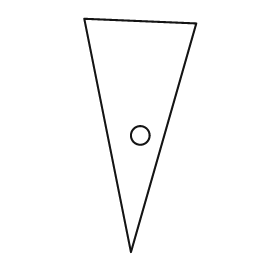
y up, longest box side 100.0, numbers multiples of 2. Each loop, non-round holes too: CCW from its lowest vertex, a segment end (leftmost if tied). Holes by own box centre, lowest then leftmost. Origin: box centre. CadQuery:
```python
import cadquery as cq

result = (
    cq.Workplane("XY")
    .moveTo(-4.0, -50.0)
    .lineTo(24.0, 48.0)
    .lineTo(-24.0, 50.0)
    .close()
    .moveTo(0.0, 0.0)
    .circle(4.0)
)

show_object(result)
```